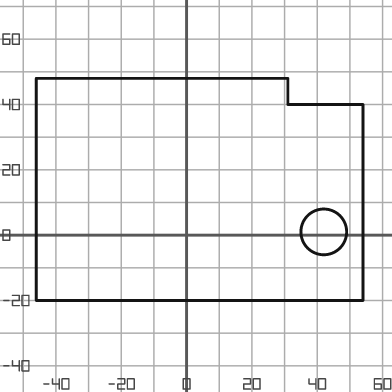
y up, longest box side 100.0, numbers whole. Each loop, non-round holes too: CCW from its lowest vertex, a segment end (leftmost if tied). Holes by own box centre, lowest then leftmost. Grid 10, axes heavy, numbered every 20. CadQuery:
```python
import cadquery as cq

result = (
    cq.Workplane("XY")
    .moveTo(-46.0, -20.0)
    .lineTo(54.0, -20.0)
    .lineTo(54.0, 40.0)
    .lineTo(31.0, 40.0)
    .lineTo(31.0, 48.0)
    .lineTo(-46.0, 48.0)
    .close()
    .moveTo(42.0, 1.0)
    .circle(7.0)
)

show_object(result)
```